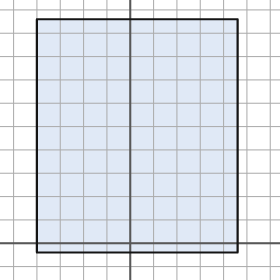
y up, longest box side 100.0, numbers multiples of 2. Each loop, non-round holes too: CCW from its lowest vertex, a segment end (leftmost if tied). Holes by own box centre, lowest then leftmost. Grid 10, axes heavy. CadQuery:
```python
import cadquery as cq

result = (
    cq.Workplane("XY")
    .moveTo(-40.0, -4.0)
    .lineTo(46.0, -4.0)
    .lineTo(46.0, 96.0)
    .lineTo(-40.0, 96.0)
    .close()
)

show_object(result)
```